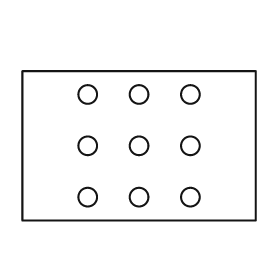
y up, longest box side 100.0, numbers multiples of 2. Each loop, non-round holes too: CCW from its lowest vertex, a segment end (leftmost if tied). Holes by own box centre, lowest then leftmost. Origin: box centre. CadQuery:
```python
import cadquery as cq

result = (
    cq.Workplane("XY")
    .moveTo(-50.0, -32.0)
    .lineTo(50.0, -32.0)
    .lineTo(50.0, 32.0)
    .lineTo(-50.0, 32.0)
    .close()
    .moveTo(-22.0, -22.0)
    .circle(4.0)
    .moveTo(0.0, -22.0)
    .circle(4.0)
    .moveTo(22.0, -22.0)
    .circle(4.0)
    .moveTo(-22.0, 0.0)
    .circle(4.0)
    .moveTo(0.0, 0.0)
    .circle(4.0)
    .moveTo(22.0, 0.0)
    .circle(4.0)
    .moveTo(-22.0, 22.0)
    .circle(4.0)
    .moveTo(0.0, 22.0)
    .circle(4.0)
    .moveTo(22.0, 22.0)
    .circle(4.0)
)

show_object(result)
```